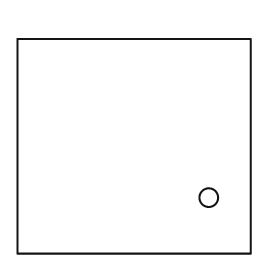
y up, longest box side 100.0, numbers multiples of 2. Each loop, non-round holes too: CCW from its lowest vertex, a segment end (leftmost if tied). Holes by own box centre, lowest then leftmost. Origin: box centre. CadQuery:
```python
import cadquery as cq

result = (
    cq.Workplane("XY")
    .moveTo(-50.0, -46.0)
    .lineTo(50.0, -46.0)
    .lineTo(50.0, 46.0)
    .lineTo(-50.0, 46.0)
    .close()
    .moveTo(32.0, -22.0)
    .circle(4.0)
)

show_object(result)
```